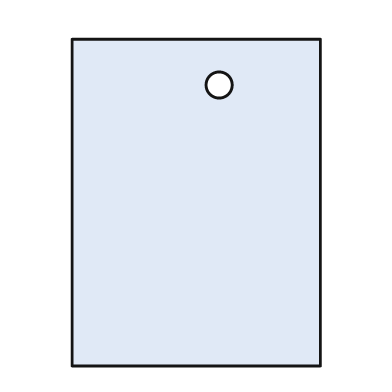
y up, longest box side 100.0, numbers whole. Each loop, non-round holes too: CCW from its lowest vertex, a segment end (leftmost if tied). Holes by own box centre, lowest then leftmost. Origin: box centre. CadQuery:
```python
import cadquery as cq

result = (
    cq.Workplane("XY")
    .moveTo(-38.0, -50.0)
    .lineTo(38.0, -50.0)
    .lineTo(38.0, 50.0)
    .lineTo(-38.0, 50.0)
    .close()
    .moveTo(7.0, 36.0)
    .circle(4.0)
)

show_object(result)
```